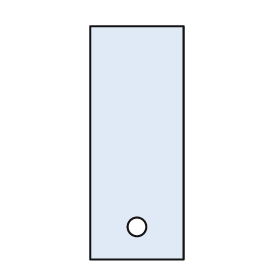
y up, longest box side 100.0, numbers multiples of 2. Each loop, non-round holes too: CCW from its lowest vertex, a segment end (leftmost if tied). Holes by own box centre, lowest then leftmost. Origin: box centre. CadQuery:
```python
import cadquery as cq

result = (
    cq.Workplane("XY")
    .moveTo(-20.0, -50.0)
    .lineTo(20.0, -50.0)
    .lineTo(20.0, 50.0)
    .lineTo(-20.0, 50.0)
    .close()
    .moveTo(0.0, -36.0)
    .circle(4.0)
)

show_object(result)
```